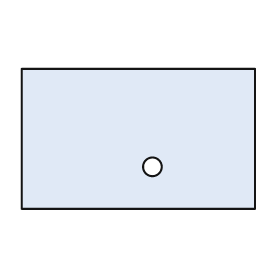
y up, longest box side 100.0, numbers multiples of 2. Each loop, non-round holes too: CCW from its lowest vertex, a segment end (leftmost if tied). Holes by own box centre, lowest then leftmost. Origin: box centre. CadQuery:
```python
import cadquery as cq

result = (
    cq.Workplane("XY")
    .moveTo(-50.0, -30.0)
    .lineTo(50.0, -30.0)
    .lineTo(50.0, 30.0)
    .lineTo(-50.0, 30.0)
    .close()
    .moveTo(6.0, -12.0)
    .circle(4.0)
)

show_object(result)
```